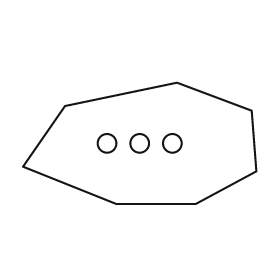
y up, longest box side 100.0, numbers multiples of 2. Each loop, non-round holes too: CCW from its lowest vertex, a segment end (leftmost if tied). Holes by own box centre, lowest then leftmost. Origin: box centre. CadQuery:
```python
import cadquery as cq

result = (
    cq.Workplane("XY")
    .moveTo(-10.0, -26.0)
    .lineTo(24.0, -26.0)
    .lineTo(50.0, -12.0)
    .lineTo(48.0, 14.0)
    .lineTo(16.0, 26.0)
    .lineTo(-32.0, 16.0)
    .lineTo(-50.0, -10.0)
    .close()
    .moveTo(-14.0, 0.0)
    .circle(4.0)
    .moveTo(0.0, 0.0)
    .circle(4.0)
    .moveTo(14.0, 0.0)
    .circle(4.0)
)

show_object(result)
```